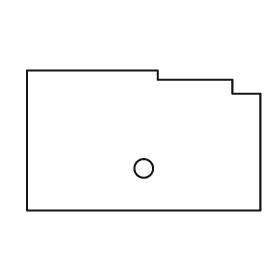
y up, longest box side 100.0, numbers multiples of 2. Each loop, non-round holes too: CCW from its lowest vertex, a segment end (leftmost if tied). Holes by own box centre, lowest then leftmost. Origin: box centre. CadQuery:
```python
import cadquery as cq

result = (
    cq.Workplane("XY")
    .moveTo(-50.0, -30.0)
    .lineTo(50.0, -30.0)
    .lineTo(50.0, 20.0)
    .lineTo(38.0, 20.0)
    .lineTo(38.0, 26.0)
    .lineTo(6.0, 26.0)
    .lineTo(6.0, 30.0)
    .lineTo(-50.0, 30.0)
    .close()
    .moveTo(0.0, -12.0)
    .circle(4.0)
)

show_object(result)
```